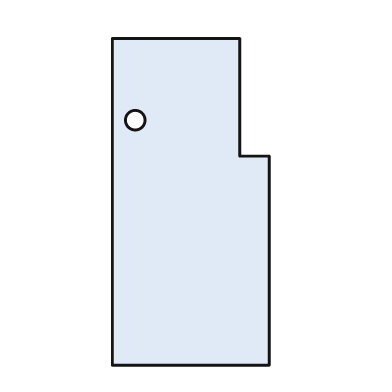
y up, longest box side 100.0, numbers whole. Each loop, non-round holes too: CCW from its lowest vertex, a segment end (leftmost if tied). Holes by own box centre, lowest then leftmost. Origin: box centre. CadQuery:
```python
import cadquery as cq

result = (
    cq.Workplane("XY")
    .moveTo(-24.0, -50.0)
    .lineTo(24.0, -50.0)
    .lineTo(24.0, 14.0)
    .lineTo(15.0, 14.0)
    .lineTo(15.0, 50.0)
    .lineTo(-24.0, 50.0)
    .close()
    .moveTo(-17.0, 25.0)
    .circle(3.0)
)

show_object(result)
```